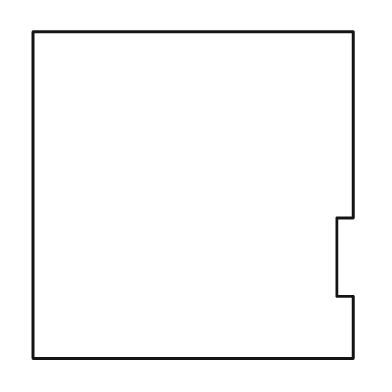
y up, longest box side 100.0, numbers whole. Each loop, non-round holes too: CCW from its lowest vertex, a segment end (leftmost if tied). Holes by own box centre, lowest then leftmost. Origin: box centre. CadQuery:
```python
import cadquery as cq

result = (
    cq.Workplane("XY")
    .moveTo(-49.0, -50.0)
    .lineTo(49.0, -50.0)
    .lineTo(49.0, -31.0)
    .lineTo(44.0, -31.0)
    .lineTo(44.0, -7.0)
    .lineTo(49.0, -7.0)
    .lineTo(49.0, 50.0)
    .lineTo(-49.0, 50.0)
    .close()
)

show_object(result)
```